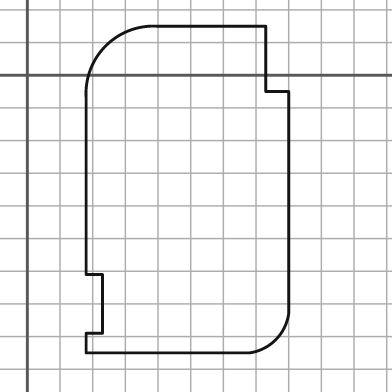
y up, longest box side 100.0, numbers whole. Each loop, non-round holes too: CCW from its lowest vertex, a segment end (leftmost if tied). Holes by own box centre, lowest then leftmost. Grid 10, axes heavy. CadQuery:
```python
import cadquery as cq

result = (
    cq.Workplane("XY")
    .moveTo(18.0, -85.0)
    .lineTo(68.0, -85.0)
    .threePointArc((76.0, -81.0), (80.0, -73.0))
    .lineTo(80.0, -5.0)
    .lineTo(73.0, -5.0)
    .lineTo(73.0, 15.0)
    .lineTo(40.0, 15.0)
    .threePointArc((24.0, 9.0), (18.0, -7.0))
    .lineTo(18.0, -61.0)
    .lineTo(23.0, -61.0)
    .lineTo(23.0, -79.0)
    .lineTo(18.0, -79.0)
    .close()
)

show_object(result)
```